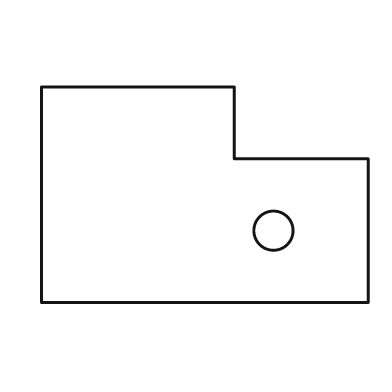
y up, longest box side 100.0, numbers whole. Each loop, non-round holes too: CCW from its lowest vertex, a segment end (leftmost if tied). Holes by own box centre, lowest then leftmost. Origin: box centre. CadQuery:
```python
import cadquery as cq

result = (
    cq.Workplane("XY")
    .moveTo(-50.0, -33.0)
    .lineTo(50.0, -33.0)
    .lineTo(50.0, 11.0)
    .lineTo(9.0, 11.0)
    .lineTo(9.0, 33.0)
    .lineTo(-50.0, 33.0)
    .close()
    .moveTo(21.0, -11.0)
    .circle(6.0)
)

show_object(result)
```